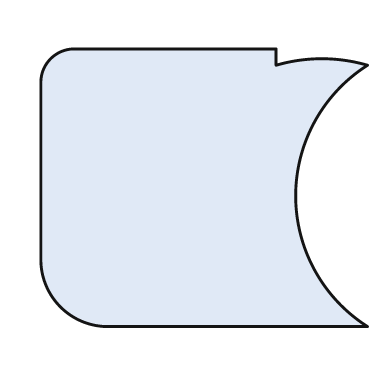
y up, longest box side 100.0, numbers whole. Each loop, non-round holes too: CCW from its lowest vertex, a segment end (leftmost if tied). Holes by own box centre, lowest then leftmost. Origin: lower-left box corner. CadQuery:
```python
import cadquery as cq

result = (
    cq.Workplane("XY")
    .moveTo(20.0, 0.0)
    .lineTo(100.0, 0.0)
    .threePointArc((78.0, 40.0), (100.0, 80.0))
    .threePointArc((86.0, 82.0), (72.0, 80.0))
    .lineTo(72.0, 85.0)
    .lineTo(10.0, 85.0)
    .threePointArc((3.0, 82.0), (0.0, 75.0))
    .lineTo(0.0, 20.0)
    .threePointArc((6.0, 6.0), (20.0, 0.0))
    .close()
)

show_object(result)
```